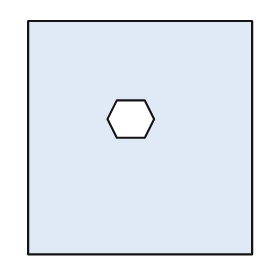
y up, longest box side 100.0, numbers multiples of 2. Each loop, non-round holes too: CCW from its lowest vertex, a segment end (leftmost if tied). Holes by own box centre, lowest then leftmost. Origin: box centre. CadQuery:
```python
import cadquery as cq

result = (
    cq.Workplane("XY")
    .moveTo(-48.0, -50.0)
    .lineTo(48.0, -50.0)
    .lineTo(48.0, 50.0)
    .lineTo(-48.0, 50.0)
    .close()
    .moveTo(-10.0, 0.0)
    .lineTo(2.0, 0.0)
    .lineTo(6.0, 8.0)
    .lineTo(2.0, 16.0)
    .lineTo(-10.0, 16.0)
    .lineTo(-14.0, 8.0)
    .close()
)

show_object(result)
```